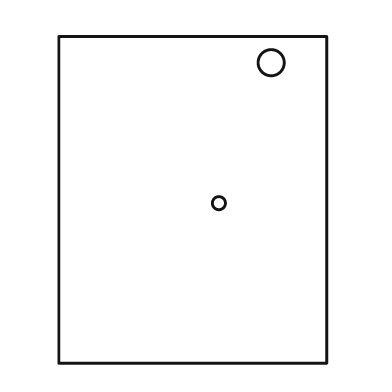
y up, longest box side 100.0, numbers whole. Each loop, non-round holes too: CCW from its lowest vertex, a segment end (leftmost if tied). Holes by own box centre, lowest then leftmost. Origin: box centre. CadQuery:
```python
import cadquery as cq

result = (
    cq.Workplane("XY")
    .moveTo(-41.0, -50.0)
    .lineTo(41.0, -50.0)
    .lineTo(41.0, 50.0)
    .lineTo(-41.0, 50.0)
    .close()
    .moveTo(8.0, -1.0)
    .circle(2.0)
    .moveTo(24.0, 42.0)
    .circle(4.0)
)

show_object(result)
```